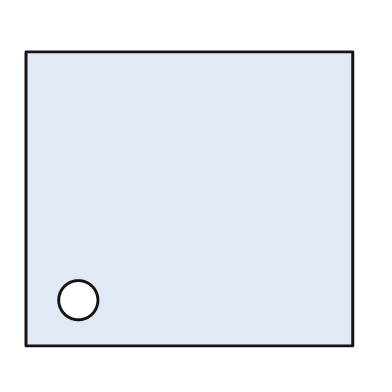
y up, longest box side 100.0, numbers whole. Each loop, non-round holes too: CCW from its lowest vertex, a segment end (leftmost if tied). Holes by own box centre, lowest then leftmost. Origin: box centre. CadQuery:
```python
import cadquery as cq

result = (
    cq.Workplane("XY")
    .moveTo(-50.0, -45.0)
    .lineTo(50.0, -45.0)
    .lineTo(50.0, 45.0)
    .lineTo(-50.0, 45.0)
    .close()
    .moveTo(-34.0, -31.0)
    .circle(6.0)
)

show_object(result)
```